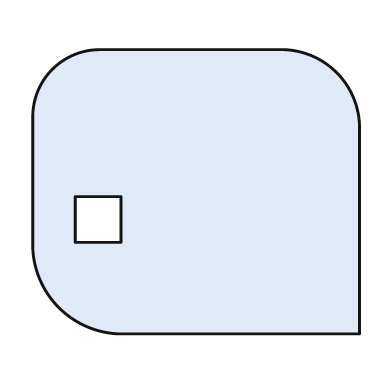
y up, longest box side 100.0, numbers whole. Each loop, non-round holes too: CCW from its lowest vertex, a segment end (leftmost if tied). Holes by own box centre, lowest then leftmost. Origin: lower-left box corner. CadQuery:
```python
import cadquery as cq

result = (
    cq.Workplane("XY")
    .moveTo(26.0, 0.0)
    .lineTo(100.0, 0.0)
    .lineTo(100.0, 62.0)
    .threePointArc((93.0, 80.0), (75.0, 87.0))
    .lineTo(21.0, 87.0)
    .threePointArc((6.0, 81.0), (0.0, 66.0))
    .lineTo(0.0, 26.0)
    .threePointArc((8.0, 8.0), (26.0, 0.0))
    .close()
    .moveTo(13.0, 28.0)
    .lineTo(27.0, 28.0)
    .lineTo(27.0, 42.0)
    .lineTo(13.0, 42.0)
    .close()
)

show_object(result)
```